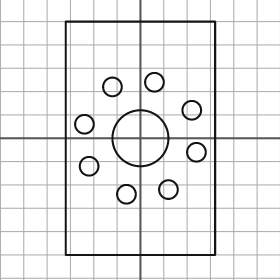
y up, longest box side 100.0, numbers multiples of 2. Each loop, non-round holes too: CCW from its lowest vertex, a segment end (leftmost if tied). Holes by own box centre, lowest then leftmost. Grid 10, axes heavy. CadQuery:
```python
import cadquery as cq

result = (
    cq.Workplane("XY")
    .moveTo(-32.0, -50.0)
    .lineTo(32.0, -50.0)
    .lineTo(32.0, 50.0)
    .lineTo(-32.0, 50.0)
    .close()
    .moveTo(-6.0, -24.0)
    .circle(4.0)
    .moveTo(12.0, -22.0)
    .circle(4.0)
    .moveTo(-22.0, -12.0)
    .circle(4.0)
    .moveTo(24.0, -6.0)
    .circle(4.0)
    .moveTo(0.0, 0.0)
    .circle(12.0)
    .moveTo(-24.0, 6.0)
    .circle(4.0)
    .moveTo(22.0, 12.0)
    .circle(4.0)
    .moveTo(-12.0, 22.0)
    .circle(4.0)
    .moveTo(6.0, 24.0)
    .circle(4.0)
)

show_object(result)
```